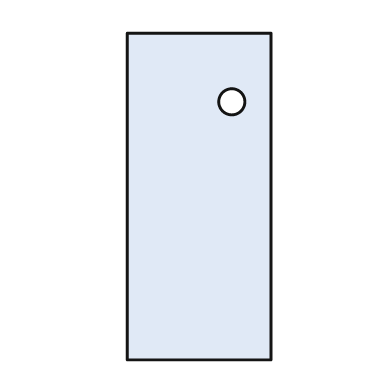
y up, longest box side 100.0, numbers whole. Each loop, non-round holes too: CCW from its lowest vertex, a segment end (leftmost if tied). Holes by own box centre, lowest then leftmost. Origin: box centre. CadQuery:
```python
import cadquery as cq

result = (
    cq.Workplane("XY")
    .moveTo(-22.0, -50.0)
    .lineTo(22.0, -50.0)
    .lineTo(22.0, 50.0)
    .lineTo(-22.0, 50.0)
    .close()
    .moveTo(10.0, 29.0)
    .circle(4.0)
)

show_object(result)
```